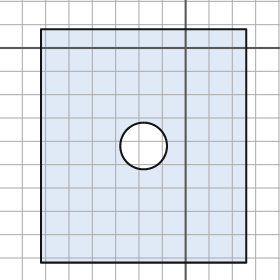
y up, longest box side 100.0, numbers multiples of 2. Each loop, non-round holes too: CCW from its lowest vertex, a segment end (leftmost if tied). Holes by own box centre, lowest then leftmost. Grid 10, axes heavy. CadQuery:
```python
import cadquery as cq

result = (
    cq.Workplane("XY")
    .moveTo(-62.0, -92.0)
    .lineTo(26.0, -92.0)
    .lineTo(26.0, 8.0)
    .lineTo(-62.0, 8.0)
    .close()
    .moveTo(-18.0, -42.0)
    .circle(10.0)
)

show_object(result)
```